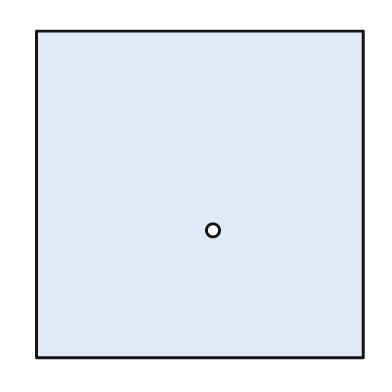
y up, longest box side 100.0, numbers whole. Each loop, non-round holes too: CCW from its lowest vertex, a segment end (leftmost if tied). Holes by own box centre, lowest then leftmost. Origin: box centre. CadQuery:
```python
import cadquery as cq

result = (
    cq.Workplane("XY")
    .moveTo(-50.0, -50.0)
    .lineTo(50.0, -50.0)
    .lineTo(50.0, 50.0)
    .lineTo(-50.0, 50.0)
    .close()
    .moveTo(4.0, -11.0)
    .circle(2.0)
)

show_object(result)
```